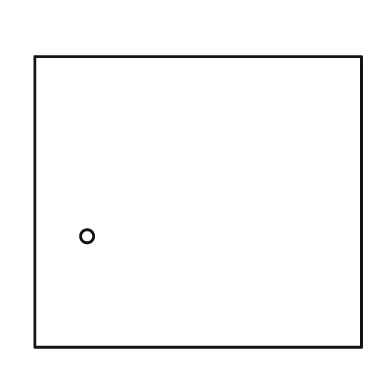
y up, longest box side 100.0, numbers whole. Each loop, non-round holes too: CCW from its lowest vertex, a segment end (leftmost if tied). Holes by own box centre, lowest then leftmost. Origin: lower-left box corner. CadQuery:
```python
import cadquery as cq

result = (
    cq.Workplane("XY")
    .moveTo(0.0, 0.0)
    .lineTo(100.0, 0.0)
    .lineTo(100.0, 89.0)
    .lineTo(0.0, 89.0)
    .close()
    .moveTo(16.0, 34.0)
    .circle(2.0)
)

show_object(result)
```